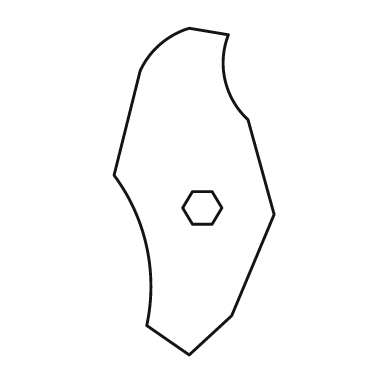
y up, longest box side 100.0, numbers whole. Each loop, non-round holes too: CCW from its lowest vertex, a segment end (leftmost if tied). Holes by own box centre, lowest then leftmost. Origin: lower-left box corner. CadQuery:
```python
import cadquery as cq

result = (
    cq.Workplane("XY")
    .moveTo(23.0, 0.0)
    .lineTo(36.0, 12.0)
    .lineTo(49.0, 43.0)
    .lineTo(41.0, 72.0)
    .threePointArc((34.0, 84.0), (35.0, 98.0))
    .lineTo(23.0, 100.0)
    .threePointArc((14.0, 95.0), (8.0, 87.0))
    .lineTo(0.0, 55.0)
    .threePointArc((10.0, 33.0), (10.0, 9.0))
    .close()
    .moveTo(24.0, 40.0)
    .lineTo(30.0, 40.0)
    .lineTo(33.0, 45.0)
    .lineTo(30.0, 50.0)
    .lineTo(24.0, 50.0)
    .lineTo(21.0, 45.0)
    .close()
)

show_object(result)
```